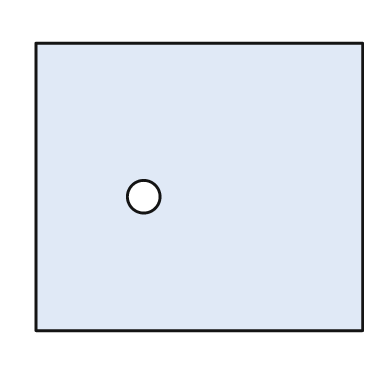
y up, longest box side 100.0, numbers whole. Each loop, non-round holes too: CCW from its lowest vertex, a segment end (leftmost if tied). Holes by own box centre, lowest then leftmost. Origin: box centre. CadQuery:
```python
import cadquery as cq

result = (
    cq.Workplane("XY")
    .moveTo(-50.0, -44.0)
    .lineTo(50.0, -44.0)
    .lineTo(50.0, 44.0)
    .lineTo(-50.0, 44.0)
    .close()
    .moveTo(-17.0, -3.0)
    .circle(5.0)
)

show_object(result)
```